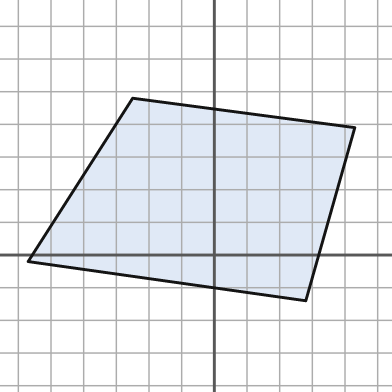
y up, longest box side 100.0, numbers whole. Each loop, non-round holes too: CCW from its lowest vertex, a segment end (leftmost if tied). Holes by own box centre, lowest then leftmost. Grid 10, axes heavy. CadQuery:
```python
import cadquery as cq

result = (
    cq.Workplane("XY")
    .moveTo(28.0, -14.0)
    .lineTo(43.0, 39.0)
    .lineTo(-25.0, 48.0)
    .lineTo(-57.0, -2.0)
    .close()
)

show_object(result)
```